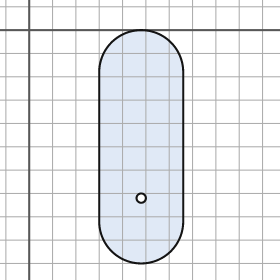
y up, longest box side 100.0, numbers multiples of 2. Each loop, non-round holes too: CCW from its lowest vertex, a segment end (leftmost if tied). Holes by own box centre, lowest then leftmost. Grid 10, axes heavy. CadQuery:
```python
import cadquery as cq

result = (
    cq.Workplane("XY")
    .moveTo(30.0, -82.0)
    .threePointArc((48.0, -100.0), (66.0, -82.0))
    .lineTo(66.0, -18.0)
    .threePointArc((48.0, 0.0), (30.0, -18.0))
    .close()
    .moveTo(48.0, -72.0)
    .circle(2.0)
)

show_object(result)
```